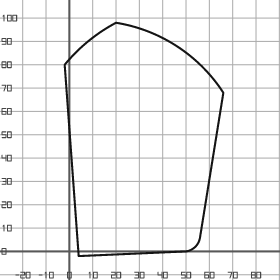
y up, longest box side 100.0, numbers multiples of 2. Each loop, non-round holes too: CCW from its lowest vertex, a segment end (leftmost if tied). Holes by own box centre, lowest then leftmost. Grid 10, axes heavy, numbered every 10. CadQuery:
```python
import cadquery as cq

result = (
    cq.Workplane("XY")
    .moveTo(4.0, -2.0)
    .lineTo(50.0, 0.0)
    .threePointArc((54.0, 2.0), (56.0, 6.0))
    .lineTo(66.0, 68.0)
    .threePointArc((46.0, 88.0), (20.0, 98.0))
    .threePointArc((8.0, 90.0), (-2.0, 80.0))
    .close()
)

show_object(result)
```